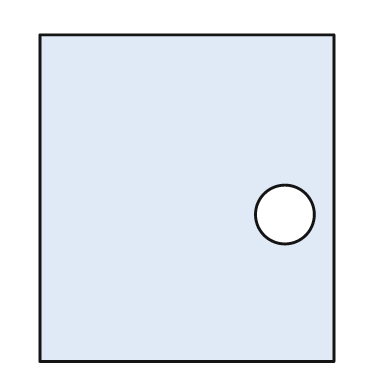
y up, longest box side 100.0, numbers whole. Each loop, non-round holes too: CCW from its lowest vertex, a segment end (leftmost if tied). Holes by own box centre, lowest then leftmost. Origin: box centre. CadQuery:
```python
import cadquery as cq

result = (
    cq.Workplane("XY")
    .moveTo(-45.0, -50.0)
    .lineTo(45.0, -50.0)
    .lineTo(45.0, 50.0)
    .lineTo(-45.0, 50.0)
    .close()
    .moveTo(30.0, -5.0)
    .circle(9.0)
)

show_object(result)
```